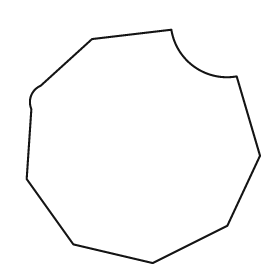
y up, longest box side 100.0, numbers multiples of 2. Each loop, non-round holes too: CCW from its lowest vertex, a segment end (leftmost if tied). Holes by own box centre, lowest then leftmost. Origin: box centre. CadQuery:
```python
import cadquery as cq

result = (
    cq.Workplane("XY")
    .moveTo(4.0, -50.0)
    .lineTo(36.0, -34.0)
    .lineTo(50.0, -4.0)
    .lineTo(40.0, 30.0)
    .threePointArc((22.0, 34.0), (12.0, 50.0))
    .lineTo(-22.0, 46.0)
    .lineTo(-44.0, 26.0)
    .threePointArc((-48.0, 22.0), (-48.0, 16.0))
    .lineTo(-50.0, -14.0)
    .lineTo(-30.0, -42.0)
    .close()
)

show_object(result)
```